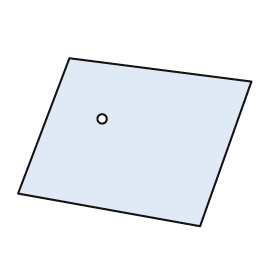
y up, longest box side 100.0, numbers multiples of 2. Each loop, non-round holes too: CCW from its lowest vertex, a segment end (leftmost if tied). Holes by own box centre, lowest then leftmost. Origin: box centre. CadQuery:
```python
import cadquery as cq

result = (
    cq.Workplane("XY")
    .moveTo(28.0, -36.0)
    .lineTo(50.0, 26.0)
    .lineTo(-28.0, 36.0)
    .lineTo(-50.0, -22.0)
    .close()
    .moveTo(-14.0, 10.0)
    .circle(2.0)
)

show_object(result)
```